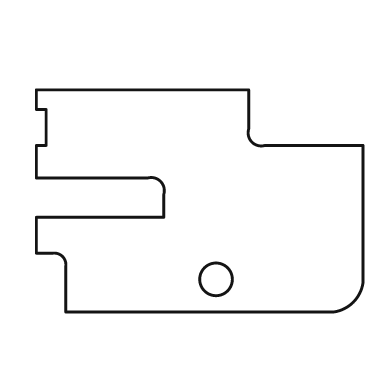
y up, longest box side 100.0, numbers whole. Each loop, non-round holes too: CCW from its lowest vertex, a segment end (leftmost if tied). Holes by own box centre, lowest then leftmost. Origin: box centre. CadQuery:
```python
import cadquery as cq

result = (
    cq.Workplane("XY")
    .moveTo(-41.0, -34.0)
    .lineTo(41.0, -34.0)
    .threePointArc((47.0, -31.0), (50.0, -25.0))
    .lineTo(50.0, 17.0)
    .lineTo(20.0, 17.0)
    .threePointArc((16.0, 18.0), (15.0, 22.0))
    .lineTo(15.0, 34.0)
    .lineTo(-50.0, 34.0)
    .lineTo(-50.0, 28.0)
    .lineTo(-47.0, 28.0)
    .lineTo(-47.0, 17.0)
    .lineTo(-50.0, 17.0)
    .lineTo(-50.0, 7.0)
    .lineTo(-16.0, 7.0)
    .threePointArc((-12.0, 6.0), (-11.0, 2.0))
    .lineTo(-11.0, -5.0)
    .lineTo(-50.0, -5.0)
    .lineTo(-50.0, -16.0)
    .lineTo(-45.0, -16.0)
    .threePointArc((-42.0, -17.0), (-41.0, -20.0))
    .close()
    .moveTo(5.0, -24.0)
    .circle(5.0)
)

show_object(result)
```